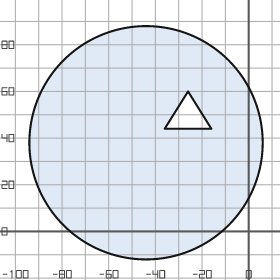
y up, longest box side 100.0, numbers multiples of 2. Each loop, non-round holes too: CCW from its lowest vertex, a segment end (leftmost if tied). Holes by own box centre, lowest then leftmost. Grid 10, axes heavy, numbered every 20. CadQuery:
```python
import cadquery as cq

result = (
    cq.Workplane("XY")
    .moveTo(-44.0, 38.0)
    .circle(50.0)
    .moveTo(-36.0, 44.0)
    .lineTo(-16.0, 44.0)
    .lineTo(-26.0, 60.0)
    .close()
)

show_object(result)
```